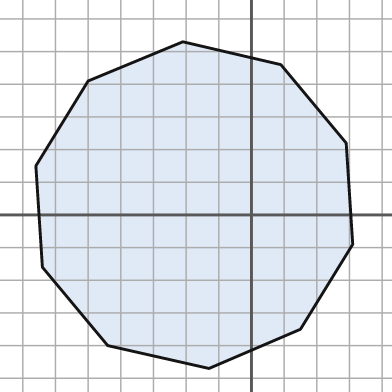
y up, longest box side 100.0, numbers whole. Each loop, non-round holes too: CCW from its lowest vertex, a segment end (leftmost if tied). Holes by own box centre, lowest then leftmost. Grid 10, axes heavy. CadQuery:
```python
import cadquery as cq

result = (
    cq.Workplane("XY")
    .moveTo(-13.0, -47.0)
    .lineTo(15.0, -35.0)
    .lineTo(31.0, -9.0)
    .lineTo(29.0, 22.0)
    .lineTo(9.0, 46.0)
    .lineTo(-21.0, 53.0)
    .lineTo(-50.0, 41.0)
    .lineTo(-66.0, 15.0)
    .lineTo(-64.0, -16.0)
    .lineTo(-44.0, -40.0)
    .close()
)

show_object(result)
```